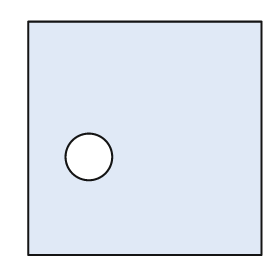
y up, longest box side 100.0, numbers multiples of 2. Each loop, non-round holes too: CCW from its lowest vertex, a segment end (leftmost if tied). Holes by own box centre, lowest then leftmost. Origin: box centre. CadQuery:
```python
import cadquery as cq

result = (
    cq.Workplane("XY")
    .moveTo(-50.0, -50.0)
    .lineTo(50.0, -50.0)
    .lineTo(50.0, 50.0)
    .lineTo(-50.0, 50.0)
    .close()
    .moveTo(-24.0, -8.0)
    .circle(10.0)
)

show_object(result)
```